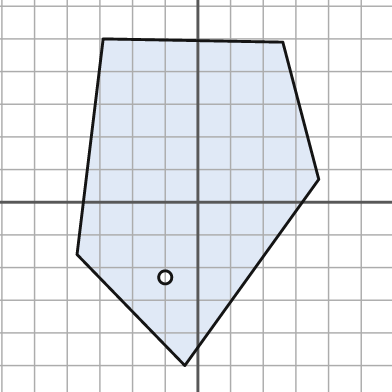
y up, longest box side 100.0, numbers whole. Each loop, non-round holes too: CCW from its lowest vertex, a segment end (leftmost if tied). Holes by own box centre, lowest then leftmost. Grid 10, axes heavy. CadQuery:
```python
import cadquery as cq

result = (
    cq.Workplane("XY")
    .moveTo(-4.0, -50.0)
    .lineTo(37.0, 7.0)
    .lineTo(26.0, 49.0)
    .lineTo(-29.0, 50.0)
    .lineTo(-37.0, -16.0)
    .close()
    .moveTo(-10.0, -23.0)
    .circle(2.0)
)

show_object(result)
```